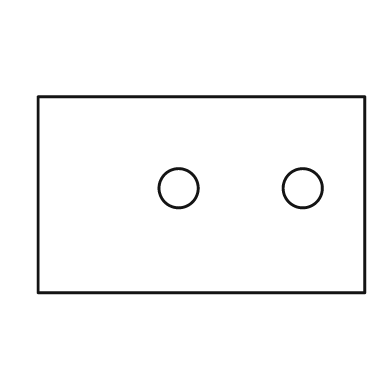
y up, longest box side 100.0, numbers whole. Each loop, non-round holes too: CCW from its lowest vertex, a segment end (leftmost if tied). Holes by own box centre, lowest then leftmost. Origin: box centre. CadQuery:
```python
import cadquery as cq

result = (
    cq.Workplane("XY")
    .moveTo(-50.0, -30.0)
    .lineTo(50.0, -30.0)
    .lineTo(50.0, 30.0)
    .lineTo(-50.0, 30.0)
    .close()
    .moveTo(-7.0, 2.0)
    .circle(6.0)
    .moveTo(31.0, 2.0)
    .circle(6.0)
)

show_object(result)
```